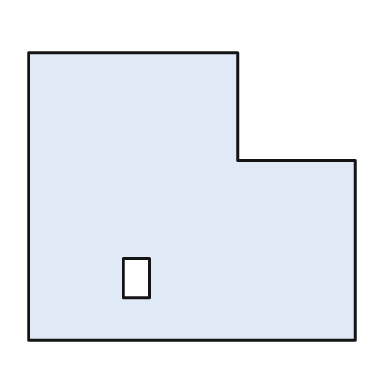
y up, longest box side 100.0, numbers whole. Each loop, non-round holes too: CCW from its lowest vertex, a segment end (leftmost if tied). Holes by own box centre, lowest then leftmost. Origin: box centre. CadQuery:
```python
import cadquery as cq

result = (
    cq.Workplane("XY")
    .moveTo(-50.0, -44.0)
    .lineTo(50.0, -44.0)
    .lineTo(50.0, 11.0)
    .lineTo(14.0, 11.0)
    .lineTo(14.0, 44.0)
    .lineTo(-50.0, 44.0)
    .close()
    .moveTo(-21.0, -31.0)
    .lineTo(-13.0, -31.0)
    .lineTo(-13.0, -19.0)
    .lineTo(-21.0, -19.0)
    .close()
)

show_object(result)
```